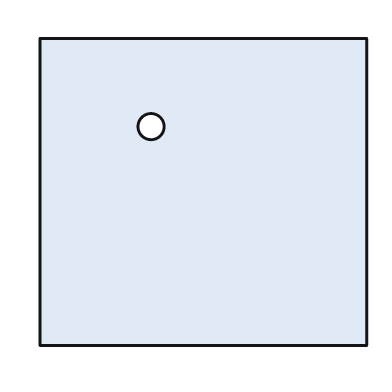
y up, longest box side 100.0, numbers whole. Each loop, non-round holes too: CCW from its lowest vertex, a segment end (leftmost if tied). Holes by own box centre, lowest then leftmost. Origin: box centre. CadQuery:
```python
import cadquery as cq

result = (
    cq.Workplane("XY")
    .moveTo(-50.0, -47.0)
    .lineTo(50.0, -47.0)
    .lineTo(50.0, 47.0)
    .lineTo(-50.0, 47.0)
    .close()
    .moveTo(-16.0, 20.0)
    .circle(4.0)
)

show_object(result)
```